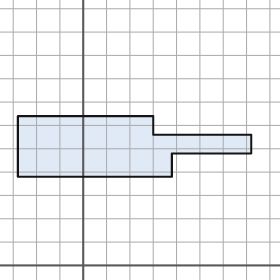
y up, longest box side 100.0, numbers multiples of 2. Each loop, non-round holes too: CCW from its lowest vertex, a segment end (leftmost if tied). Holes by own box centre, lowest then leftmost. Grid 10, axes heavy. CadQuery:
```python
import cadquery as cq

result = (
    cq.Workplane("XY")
    .moveTo(-28.0, 38.0)
    .lineTo(38.0, 38.0)
    .lineTo(38.0, 48.0)
    .lineTo(72.0, 48.0)
    .lineTo(72.0, 56.0)
    .lineTo(30.0, 56.0)
    .lineTo(30.0, 64.0)
    .lineTo(-28.0, 64.0)
    .close()
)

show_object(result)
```